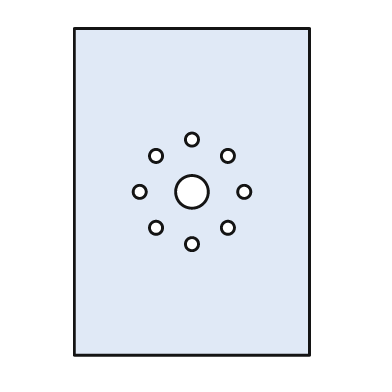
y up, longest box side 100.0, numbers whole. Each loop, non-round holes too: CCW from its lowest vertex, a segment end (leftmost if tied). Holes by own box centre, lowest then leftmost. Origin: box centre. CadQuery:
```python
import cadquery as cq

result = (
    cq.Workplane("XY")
    .moveTo(-36.0, -50.0)
    .lineTo(36.0, -50.0)
    .lineTo(36.0, 50.0)
    .lineTo(-36.0, 50.0)
    .close()
    .moveTo(0.0, -16.0)
    .circle(2.0)
    .moveTo(-11.0, -11.0)
    .circle(2.0)
    .moveTo(11.0, -11.0)
    .circle(2.0)
    .moveTo(-16.0, 0.0)
    .circle(2.0)
    .moveTo(0.0, 0.0)
    .circle(5.0)
    .moveTo(16.0, 0.0)
    .circle(2.0)
    .moveTo(-11.0, 11.0)
    .circle(2.0)
    .moveTo(11.0, 11.0)
    .circle(2.0)
    .moveTo(0.0, 16.0)
    .circle(2.0)
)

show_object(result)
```